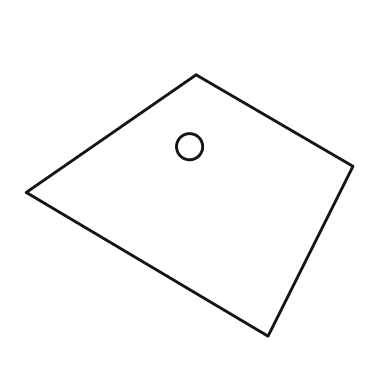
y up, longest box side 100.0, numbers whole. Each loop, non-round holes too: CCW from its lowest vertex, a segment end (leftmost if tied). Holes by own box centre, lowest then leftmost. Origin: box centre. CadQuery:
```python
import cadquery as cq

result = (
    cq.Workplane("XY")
    .moveTo(24.0, -40.0)
    .lineTo(50.0, 12.0)
    .lineTo(2.0, 40.0)
    .lineTo(-50.0, 4.0)
    .close()
    .moveTo(0.0, 18.0)
    .circle(4.0)
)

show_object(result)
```